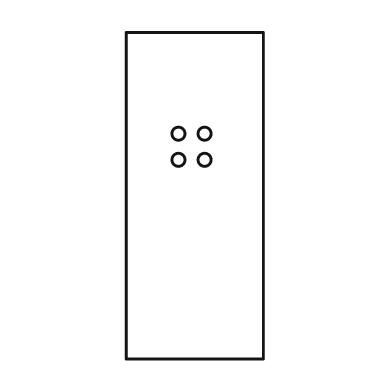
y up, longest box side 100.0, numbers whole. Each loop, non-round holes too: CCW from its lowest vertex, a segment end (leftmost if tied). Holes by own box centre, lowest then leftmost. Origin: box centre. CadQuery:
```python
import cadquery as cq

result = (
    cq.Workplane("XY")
    .moveTo(-21.0, -50.0)
    .lineTo(21.0, -50.0)
    .lineTo(21.0, 50.0)
    .lineTo(-21.0, 50.0)
    .close()
    .moveTo(-5.0, 11.0)
    .circle(2.0)
    .moveTo(3.0, 11.0)
    .circle(2.0)
    .moveTo(-5.0, 19.0)
    .circle(2.0)
    .moveTo(3.0, 19.0)
    .circle(2.0)
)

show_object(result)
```